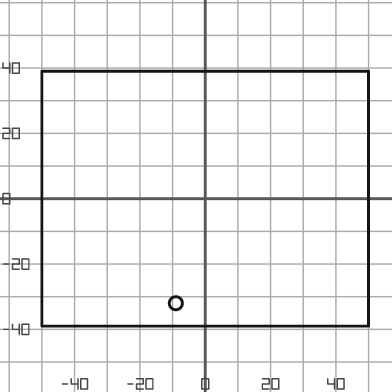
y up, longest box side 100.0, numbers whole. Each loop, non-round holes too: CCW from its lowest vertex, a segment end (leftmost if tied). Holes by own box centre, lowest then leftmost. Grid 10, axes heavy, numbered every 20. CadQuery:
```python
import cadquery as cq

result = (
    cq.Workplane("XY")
    .moveTo(-50.0, -39.0)
    .lineTo(50.0, -39.0)
    .lineTo(50.0, 39.0)
    .lineTo(-50.0, 39.0)
    .close()
    .moveTo(-9.0, -32.0)
    .circle(2.0)
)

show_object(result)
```